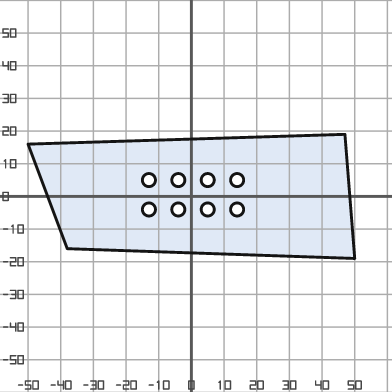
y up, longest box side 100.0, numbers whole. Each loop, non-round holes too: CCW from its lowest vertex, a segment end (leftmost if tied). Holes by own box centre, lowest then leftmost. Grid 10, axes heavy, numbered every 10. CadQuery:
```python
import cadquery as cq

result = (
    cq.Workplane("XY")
    .moveTo(50.0, -19.0)
    .lineTo(47.0, 19.0)
    .lineTo(-50.0, 16.0)
    .lineTo(-38.0, -16.0)
    .close()
    .moveTo(-13.0, -4.0)
    .circle(2.0)
    .moveTo(-4.0, -4.0)
    .circle(2.0)
    .moveTo(5.0, -4.0)
    .circle(2.0)
    .moveTo(14.0, -4.0)
    .circle(2.0)
    .moveTo(-13.0, 5.0)
    .circle(2.0)
    .moveTo(-4.0, 5.0)
    .circle(2.0)
    .moveTo(5.0, 5.0)
    .circle(2.0)
    .moveTo(14.0, 5.0)
    .circle(2.0)
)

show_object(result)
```